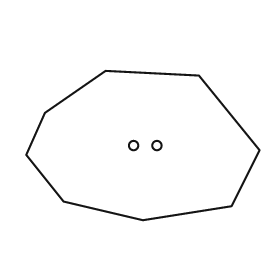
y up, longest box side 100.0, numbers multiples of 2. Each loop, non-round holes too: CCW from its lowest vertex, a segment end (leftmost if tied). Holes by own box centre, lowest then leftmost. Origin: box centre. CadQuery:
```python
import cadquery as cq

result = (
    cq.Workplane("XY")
    .moveTo(0.0, -32.0)
    .lineTo(38.0, -26.0)
    .lineTo(50.0, -2.0)
    .lineTo(24.0, 30.0)
    .lineTo(-16.0, 32.0)
    .lineTo(-42.0, 14.0)
    .lineTo(-50.0, -4.0)
    .lineTo(-34.0, -24.0)
    .close()
    .moveTo(-4.0, 0.0)
    .circle(2.0)
    .moveTo(6.0, 0.0)
    .circle(2.0)
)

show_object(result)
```